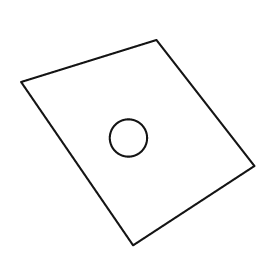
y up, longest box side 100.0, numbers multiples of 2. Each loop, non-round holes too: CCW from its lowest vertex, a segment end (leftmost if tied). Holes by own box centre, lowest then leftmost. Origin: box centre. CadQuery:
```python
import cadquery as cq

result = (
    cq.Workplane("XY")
    .moveTo(-2.0, -44.0)
    .lineTo(50.0, -10.0)
    .lineTo(8.0, 44.0)
    .lineTo(-50.0, 26.0)
    .close()
    .moveTo(-4.0, 2.0)
    .circle(8.0)
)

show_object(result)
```